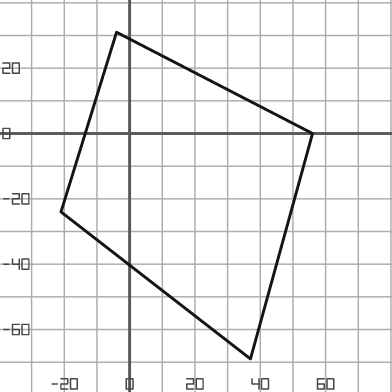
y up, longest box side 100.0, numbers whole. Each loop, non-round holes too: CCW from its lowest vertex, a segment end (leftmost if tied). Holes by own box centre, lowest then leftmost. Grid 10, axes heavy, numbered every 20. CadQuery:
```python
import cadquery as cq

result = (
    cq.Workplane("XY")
    .moveTo(37.0, -69.0)
    .lineTo(56.0, 0.0)
    .lineTo(-4.0, 31.0)
    .lineTo(-21.0, -24.0)
    .close()
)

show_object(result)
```